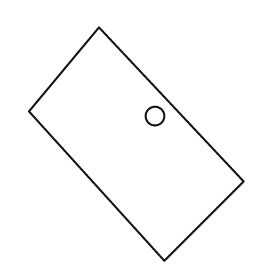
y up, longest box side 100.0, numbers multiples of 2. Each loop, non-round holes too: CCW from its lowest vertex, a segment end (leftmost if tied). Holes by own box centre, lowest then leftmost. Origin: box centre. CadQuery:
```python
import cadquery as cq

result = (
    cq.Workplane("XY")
    .moveTo(12.0, -50.0)
    .lineTo(46.0, -16.0)
    .lineTo(-16.0, 50.0)
    .lineTo(-46.0, 14.0)
    .close()
    .moveTo(8.0, 12.0)
    .circle(4.0)
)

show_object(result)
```